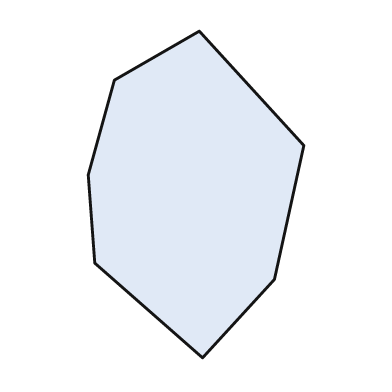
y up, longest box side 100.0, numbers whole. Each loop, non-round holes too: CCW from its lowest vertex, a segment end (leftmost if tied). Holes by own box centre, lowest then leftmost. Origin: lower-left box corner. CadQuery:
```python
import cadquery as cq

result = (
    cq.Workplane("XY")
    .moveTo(35.0, 0.0)
    .lineTo(57.0, 24.0)
    .lineTo(66.0, 65.0)
    .lineTo(34.0, 100.0)
    .lineTo(8.0, 85.0)
    .lineTo(0.0, 56.0)
    .lineTo(2.0, 29.0)
    .close()
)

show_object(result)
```